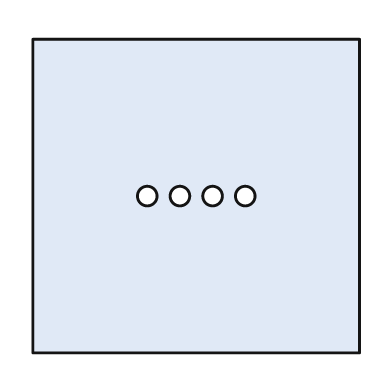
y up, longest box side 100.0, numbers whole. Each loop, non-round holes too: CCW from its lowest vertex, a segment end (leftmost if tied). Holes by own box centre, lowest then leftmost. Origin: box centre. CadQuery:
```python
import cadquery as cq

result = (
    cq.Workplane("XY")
    .moveTo(-50.0, -48.0)
    .lineTo(50.0, -48.0)
    .lineTo(50.0, 48.0)
    .lineTo(-50.0, 48.0)
    .close()
    .moveTo(-15.0, 0.0)
    .circle(3.0)
    .moveTo(-5.0, 0.0)
    .circle(3.0)
    .moveTo(5.0, 0.0)
    .circle(3.0)
    .moveTo(15.0, 0.0)
    .circle(3.0)
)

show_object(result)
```